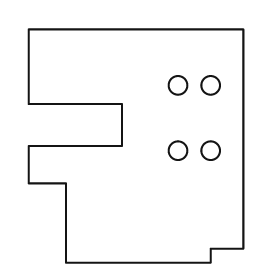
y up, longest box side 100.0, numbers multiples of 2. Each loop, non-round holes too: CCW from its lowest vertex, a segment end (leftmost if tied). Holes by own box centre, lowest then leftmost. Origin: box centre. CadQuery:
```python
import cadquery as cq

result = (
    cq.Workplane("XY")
    .moveTo(-30.0, -50.0)
    .lineTo(32.0, -50.0)
    .lineTo(32.0, -44.0)
    .lineTo(46.0, -44.0)
    .lineTo(46.0, 50.0)
    .lineTo(-46.0, 50.0)
    .lineTo(-46.0, 18.0)
    .lineTo(-6.0, 18.0)
    .lineTo(-6.0, 0.0)
    .lineTo(-46.0, 0.0)
    .lineTo(-46.0, -16.0)
    .lineTo(-30.0, -16.0)
    .close()
    .moveTo(18.0, -2.0)
    .circle(4.0)
    .moveTo(32.0, -2.0)
    .circle(4.0)
    .moveTo(18.0, 26.0)
    .circle(4.0)
    .moveTo(32.0, 26.0)
    .circle(4.0)
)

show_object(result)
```